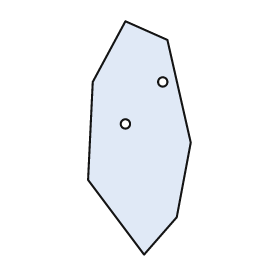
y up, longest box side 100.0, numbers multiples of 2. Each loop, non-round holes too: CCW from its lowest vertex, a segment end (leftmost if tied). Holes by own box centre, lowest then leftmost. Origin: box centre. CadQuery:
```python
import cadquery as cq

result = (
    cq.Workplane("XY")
    .moveTo(2.0, -50.0)
    .lineTo(16.0, -34.0)
    .lineTo(22.0, -2.0)
    .lineTo(12.0, 42.0)
    .lineTo(-6.0, 50.0)
    .lineTo(-20.0, 24.0)
    .lineTo(-22.0, -18.0)
    .close()
    .moveTo(-6.0, 6.0)
    .circle(2.0)
    .moveTo(10.0, 24.0)
    .circle(2.0)
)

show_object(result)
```